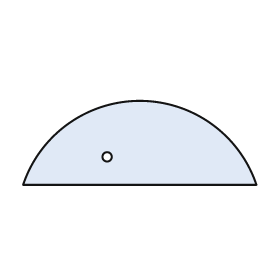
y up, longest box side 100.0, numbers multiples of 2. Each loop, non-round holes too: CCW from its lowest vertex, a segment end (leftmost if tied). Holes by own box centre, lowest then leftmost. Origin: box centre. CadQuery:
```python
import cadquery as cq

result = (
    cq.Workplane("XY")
    .moveTo(-50.0, -18.0)
    .lineTo(50.0, -18.0)
    .threePointArc((0.0, 18.0), (-50.0, -18.0))
    .close()
    .moveTo(-14.0, -6.0)
    .circle(2.0)
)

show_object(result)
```